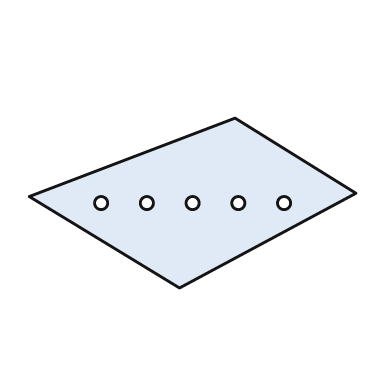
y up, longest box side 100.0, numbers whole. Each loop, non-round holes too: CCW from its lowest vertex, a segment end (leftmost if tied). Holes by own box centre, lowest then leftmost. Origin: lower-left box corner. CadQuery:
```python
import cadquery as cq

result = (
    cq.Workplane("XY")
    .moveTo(46.0, 0.0)
    .lineTo(100.0, 29.0)
    .lineTo(63.0, 52.0)
    .lineTo(0.0, 28.0)
    .close()
    .moveTo(22.0, 26.0)
    .circle(2.0)
    .moveTo(36.0, 26.0)
    .circle(2.0)
    .moveTo(50.0, 26.0)
    .circle(2.0)
    .moveTo(64.0, 26.0)
    .circle(2.0)
    .moveTo(78.0, 26.0)
    .circle(2.0)
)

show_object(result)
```